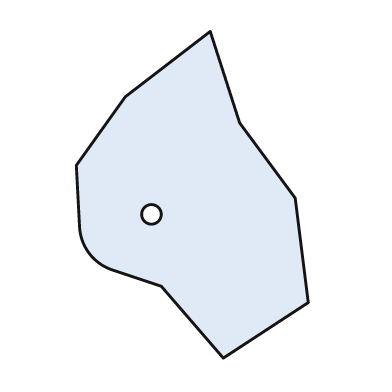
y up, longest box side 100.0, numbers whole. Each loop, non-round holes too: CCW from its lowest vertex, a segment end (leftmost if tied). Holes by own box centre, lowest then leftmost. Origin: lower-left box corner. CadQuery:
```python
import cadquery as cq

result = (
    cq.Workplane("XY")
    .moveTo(45.0, 0.0)
    .lineTo(71.0, 17.0)
    .lineTo(67.0, 49.0)
    .lineTo(50.0, 72.0)
    .lineTo(41.0, 100.0)
    .lineTo(15.0, 80.0)
    .lineTo(0.0, 59.0)
    .lineTo(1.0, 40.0)
    .threePointArc((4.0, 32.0), (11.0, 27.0))
    .lineTo(26.0, 22.0)
    .close()
    .moveTo(23.0, 44.0)
    .circle(3.0)
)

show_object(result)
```